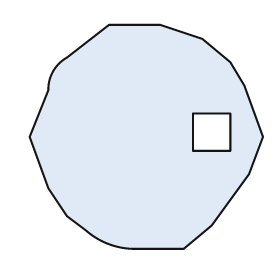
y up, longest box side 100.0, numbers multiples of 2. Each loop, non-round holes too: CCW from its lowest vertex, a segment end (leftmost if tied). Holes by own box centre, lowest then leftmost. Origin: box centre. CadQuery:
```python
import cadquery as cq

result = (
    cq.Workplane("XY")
    .moveTo(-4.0, -48.0)
    .lineTo(16.0, -48.0)
    .lineTo(28.0, -38.0)
    .lineTo(44.0, -16.0)
    .lineTo(50.0, 0.0)
    .lineTo(42.0, 22.0)
    .lineTo(36.0, 32.0)
    .lineTo(24.0, 42.0)
    .lineTo(6.0, 48.0)
    .lineTo(-16.0, 48.0)
    .lineTo(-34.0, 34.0)
    .threePointArc((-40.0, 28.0), (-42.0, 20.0))
    .lineTo(-50.0, 0.0)
    .lineTo(-42.0, -22.0)
    .lineTo(-34.0, -34.0)
    .lineTo(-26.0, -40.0)
    .threePointArc((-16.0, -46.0), (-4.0, -48.0))
    .close()
    .moveTo(20.0, -6.0)
    .lineTo(36.0, -6.0)
    .lineTo(36.0, 10.0)
    .lineTo(20.0, 10.0)
    .close()
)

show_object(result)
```